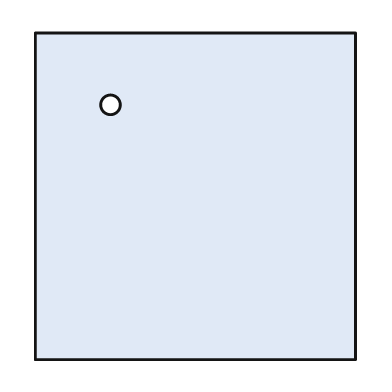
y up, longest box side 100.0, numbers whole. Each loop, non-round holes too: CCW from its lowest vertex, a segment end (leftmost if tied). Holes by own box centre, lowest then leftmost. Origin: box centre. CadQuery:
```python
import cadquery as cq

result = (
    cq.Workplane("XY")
    .moveTo(-49.0, -50.0)
    .lineTo(49.0, -50.0)
    .lineTo(49.0, 50.0)
    .lineTo(-49.0, 50.0)
    .close()
    .moveTo(-26.0, 28.0)
    .circle(3.0)
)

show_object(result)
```